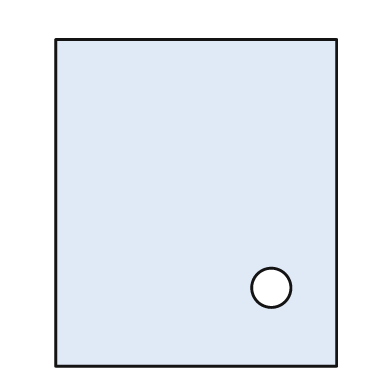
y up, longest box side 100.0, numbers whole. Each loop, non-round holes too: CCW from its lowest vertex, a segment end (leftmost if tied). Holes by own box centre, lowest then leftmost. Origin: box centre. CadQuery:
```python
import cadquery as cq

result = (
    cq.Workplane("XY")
    .moveTo(-43.0, -50.0)
    .lineTo(43.0, -50.0)
    .lineTo(43.0, 50.0)
    .lineTo(-43.0, 50.0)
    .close()
    .moveTo(23.0, -26.0)
    .circle(6.0)
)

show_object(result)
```